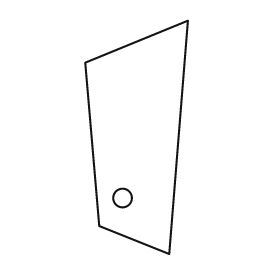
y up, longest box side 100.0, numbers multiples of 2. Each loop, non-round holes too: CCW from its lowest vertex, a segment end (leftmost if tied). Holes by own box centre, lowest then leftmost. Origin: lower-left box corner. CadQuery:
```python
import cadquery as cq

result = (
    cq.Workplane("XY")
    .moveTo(36.0, 0.0)
    .lineTo(44.0, 100.0)
    .lineTo(0.0, 82.0)
    .lineTo(6.0, 12.0)
    .close()
    .moveTo(16.0, 24.0)
    .circle(4.0)
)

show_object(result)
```